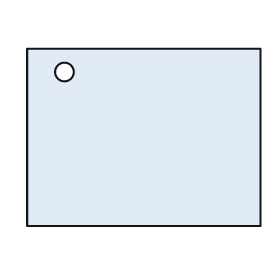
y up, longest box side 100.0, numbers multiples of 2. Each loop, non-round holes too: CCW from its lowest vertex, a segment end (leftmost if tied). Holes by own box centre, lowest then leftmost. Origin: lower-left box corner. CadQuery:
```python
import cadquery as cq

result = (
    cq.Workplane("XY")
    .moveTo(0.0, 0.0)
    .lineTo(100.0, 0.0)
    .lineTo(100.0, 76.0)
    .lineTo(0.0, 76.0)
    .close()
    .moveTo(16.0, 66.0)
    .circle(4.0)
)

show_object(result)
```